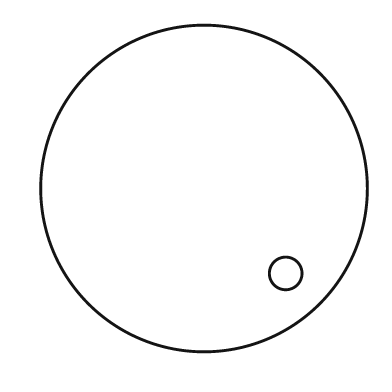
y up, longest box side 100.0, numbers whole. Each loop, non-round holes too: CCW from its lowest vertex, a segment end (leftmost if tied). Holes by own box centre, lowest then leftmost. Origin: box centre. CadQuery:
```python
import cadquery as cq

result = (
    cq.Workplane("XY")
    .moveTo(0.0, 0.0)
    .circle(50.0)
    .moveTo(25.0, -26.0)
    .circle(5.0)
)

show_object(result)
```